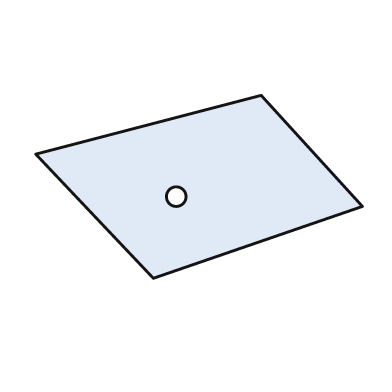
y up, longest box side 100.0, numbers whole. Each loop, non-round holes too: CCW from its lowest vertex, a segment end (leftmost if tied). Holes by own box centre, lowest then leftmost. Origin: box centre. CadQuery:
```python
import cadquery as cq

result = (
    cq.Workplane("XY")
    .moveTo(-14.0, -28.0)
    .lineTo(50.0, -6.0)
    .lineTo(19.0, 28.0)
    .lineTo(-50.0, 10.0)
    .close()
    .moveTo(-7.0, -3.0)
    .circle(3.0)
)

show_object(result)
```